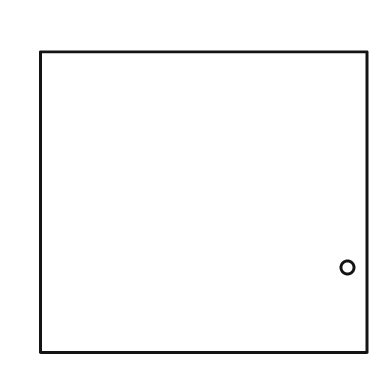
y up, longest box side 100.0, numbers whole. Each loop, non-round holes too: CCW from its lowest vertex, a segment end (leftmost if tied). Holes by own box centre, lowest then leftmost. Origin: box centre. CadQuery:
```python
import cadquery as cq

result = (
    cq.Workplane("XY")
    .moveTo(-50.0, -46.0)
    .lineTo(50.0, -46.0)
    .lineTo(50.0, 46.0)
    .lineTo(-50.0, 46.0)
    .close()
    .moveTo(44.0, -20.0)
    .circle(2.0)
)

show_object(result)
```